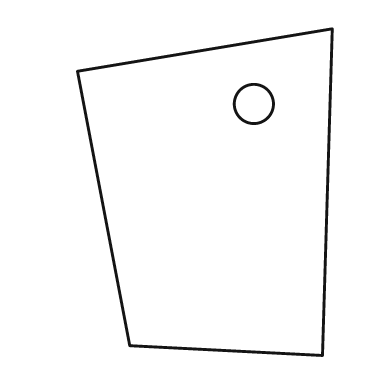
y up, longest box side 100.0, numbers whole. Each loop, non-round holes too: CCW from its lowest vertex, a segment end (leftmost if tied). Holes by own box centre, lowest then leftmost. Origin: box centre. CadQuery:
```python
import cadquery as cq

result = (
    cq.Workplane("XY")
    .moveTo(36.0, -50.0)
    .lineTo(39.0, 50.0)
    .lineTo(-39.0, 37.0)
    .lineTo(-23.0, -47.0)
    .close()
    .moveTo(15.0, 27.0)
    .circle(6.0)
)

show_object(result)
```